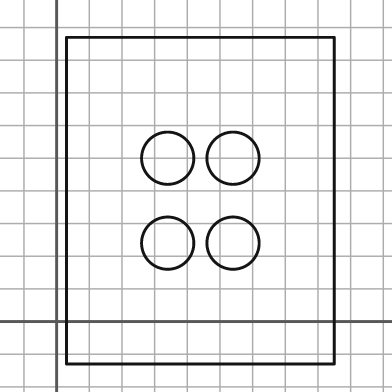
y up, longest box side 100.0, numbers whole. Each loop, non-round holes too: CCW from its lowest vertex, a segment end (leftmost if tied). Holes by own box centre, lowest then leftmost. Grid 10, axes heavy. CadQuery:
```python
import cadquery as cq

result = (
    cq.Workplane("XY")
    .moveTo(3.0, -13.0)
    .lineTo(85.0, -13.0)
    .lineTo(85.0, 87.0)
    .lineTo(3.0, 87.0)
    .close()
    .moveTo(34.0, 24.0)
    .circle(8.0)
    .moveTo(54.0, 24.0)
    .circle(8.0)
    .moveTo(34.0, 50.0)
    .circle(8.0)
    .moveTo(54.0, 50.0)
    .circle(8.0)
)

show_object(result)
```